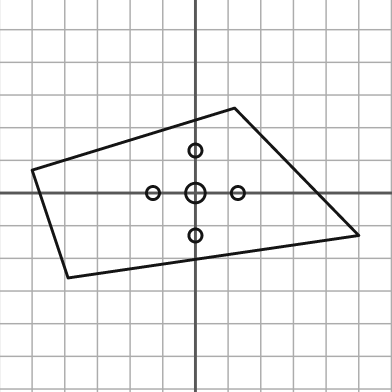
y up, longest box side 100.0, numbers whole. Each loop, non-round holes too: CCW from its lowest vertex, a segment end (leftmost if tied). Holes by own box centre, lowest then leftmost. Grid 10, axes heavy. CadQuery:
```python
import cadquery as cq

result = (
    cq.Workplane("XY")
    .moveTo(-39.0, -26.0)
    .lineTo(50.0, -13.0)
    .lineTo(12.0, 26.0)
    .lineTo(-50.0, 7.0)
    .close()
    .moveTo(0.0, -13.0)
    .circle(2.0)
    .moveTo(-13.0, 0.0)
    .circle(2.0)
    .moveTo(0.0, 0.0)
    .circle(3.0)
    .moveTo(13.0, 0.0)
    .circle(2.0)
    .moveTo(0.0, 13.0)
    .circle(2.0)
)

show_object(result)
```